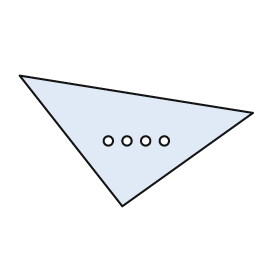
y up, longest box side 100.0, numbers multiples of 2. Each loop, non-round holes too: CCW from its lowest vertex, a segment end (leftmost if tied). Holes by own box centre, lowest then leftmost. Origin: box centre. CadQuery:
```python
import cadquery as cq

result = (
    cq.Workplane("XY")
    .moveTo(-6.0, -28.0)
    .lineTo(50.0, 12.0)
    .lineTo(-50.0, 28.0)
    .close()
    .moveTo(-12.0, 0.0)
    .circle(2.0)
    .moveTo(-4.0, 0.0)
    .circle(2.0)
    .moveTo(4.0, 0.0)
    .circle(2.0)
    .moveTo(12.0, 0.0)
    .circle(2.0)
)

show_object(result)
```